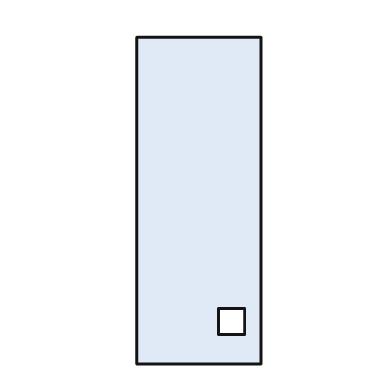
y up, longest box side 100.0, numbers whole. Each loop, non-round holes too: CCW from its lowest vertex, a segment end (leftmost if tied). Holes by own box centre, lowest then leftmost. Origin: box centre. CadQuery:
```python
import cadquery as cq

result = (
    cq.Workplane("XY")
    .moveTo(-19.0, -50.0)
    .lineTo(19.0, -50.0)
    .lineTo(19.0, 50.0)
    .lineTo(-19.0, 50.0)
    .close()
    .moveTo(6.0, -41.0)
    .lineTo(14.0, -41.0)
    .lineTo(14.0, -33.0)
    .lineTo(6.0, -33.0)
    .close()
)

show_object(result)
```